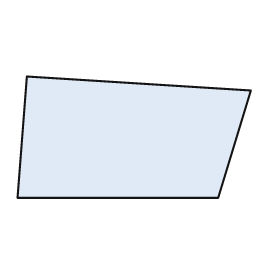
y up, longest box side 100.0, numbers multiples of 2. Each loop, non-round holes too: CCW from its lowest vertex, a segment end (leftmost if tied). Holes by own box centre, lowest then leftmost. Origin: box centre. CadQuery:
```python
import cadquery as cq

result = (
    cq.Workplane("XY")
    .moveTo(-50.0, -26.0)
    .lineTo(36.0, -26.0)
    .lineTo(50.0, 20.0)
    .lineTo(-46.0, 26.0)
    .close()
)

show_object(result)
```